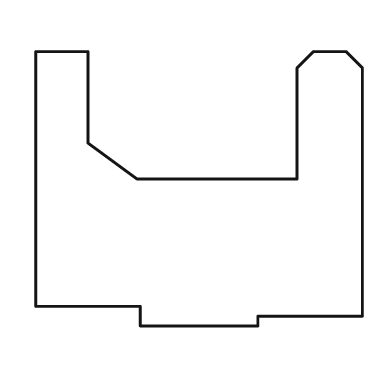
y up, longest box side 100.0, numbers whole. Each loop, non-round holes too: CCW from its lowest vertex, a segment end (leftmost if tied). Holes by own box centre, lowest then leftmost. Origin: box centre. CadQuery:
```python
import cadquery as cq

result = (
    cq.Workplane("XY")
    .moveTo(-18.0, -42.0)
    .lineTo(18.0, -42.0)
    .lineTo(18.0, -39.0)
    .lineTo(50.0, -39.0)
    .lineTo(50.0, 37.0)
    .lineTo(45.0, 42.0)
    .lineTo(35.0, 42.0)
    .lineTo(30.0, 37.0)
    .lineTo(30.0, 3.0)
    .lineTo(-19.0, 3.0)
    .lineTo(-34.0, 14.0)
    .lineTo(-34.0, 42.0)
    .lineTo(-50.0, 42.0)
    .lineTo(-50.0, -36.0)
    .lineTo(-18.0, -36.0)
    .close()
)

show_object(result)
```